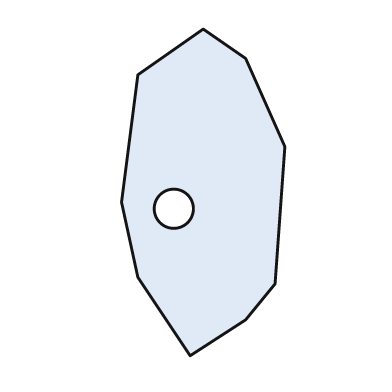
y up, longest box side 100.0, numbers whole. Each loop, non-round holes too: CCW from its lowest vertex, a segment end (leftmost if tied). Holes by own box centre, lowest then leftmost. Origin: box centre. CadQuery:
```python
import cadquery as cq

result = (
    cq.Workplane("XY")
    .moveTo(-4.0, -50.0)
    .lineTo(13.0, -39.0)
    .lineTo(22.0, -28.0)
    .lineTo(25.0, 14.0)
    .lineTo(13.0, 41.0)
    .lineTo(0.0, 50.0)
    .lineTo(-20.0, 36.0)
    .lineTo(-25.0, -3.0)
    .lineTo(-20.0, -26.0)
    .close()
    .moveTo(-9.0, -5.0)
    .circle(6.0)
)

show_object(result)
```